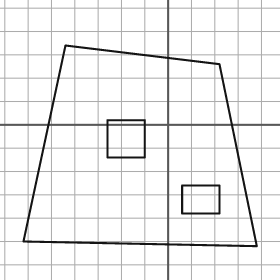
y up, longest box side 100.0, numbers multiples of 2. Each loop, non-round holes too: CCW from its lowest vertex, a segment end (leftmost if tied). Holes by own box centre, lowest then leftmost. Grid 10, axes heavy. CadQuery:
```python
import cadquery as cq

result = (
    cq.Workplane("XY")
    .moveTo(38.0, -52.0)
    .lineTo(22.0, 26.0)
    .lineTo(-44.0, 34.0)
    .lineTo(-62.0, -50.0)
    .close()
    .moveTo(6.0, -38.0)
    .lineTo(22.0, -38.0)
    .lineTo(22.0, -26.0)
    .lineTo(6.0, -26.0)
    .close()
    .moveTo(-26.0, -14.0)
    .lineTo(-10.0, -14.0)
    .lineTo(-10.0, 2.0)
    .lineTo(-26.0, 2.0)
    .close()
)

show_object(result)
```